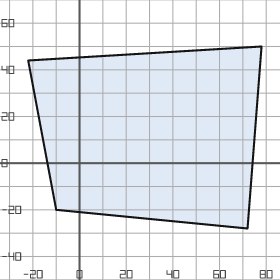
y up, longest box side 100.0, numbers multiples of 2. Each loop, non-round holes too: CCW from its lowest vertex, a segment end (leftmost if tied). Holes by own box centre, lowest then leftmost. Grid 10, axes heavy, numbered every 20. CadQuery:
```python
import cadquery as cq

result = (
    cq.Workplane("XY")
    .moveTo(72.0, -28.0)
    .lineTo(78.0, 50.0)
    .lineTo(-22.0, 44.0)
    .lineTo(-10.0, -20.0)
    .close()
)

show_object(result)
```